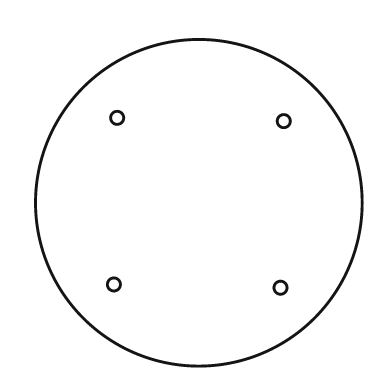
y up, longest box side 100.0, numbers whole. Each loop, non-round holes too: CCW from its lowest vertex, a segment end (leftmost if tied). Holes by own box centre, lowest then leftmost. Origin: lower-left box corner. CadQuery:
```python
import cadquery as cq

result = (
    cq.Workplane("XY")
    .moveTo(50.0, 50.0)
    .circle(50.0)
    .moveTo(75.0, 24.0)
    .circle(2.0)
    .moveTo(24.0, 25.0)
    .circle(2.0)
    .moveTo(76.0, 75.0)
    .circle(2.0)
    .moveTo(25.0, 76.0)
    .circle(2.0)
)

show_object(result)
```